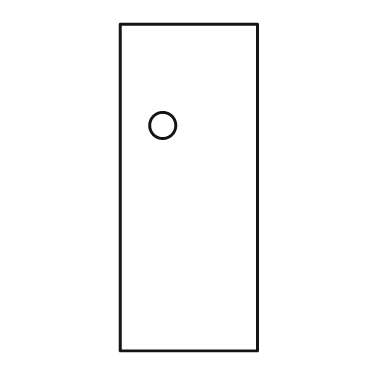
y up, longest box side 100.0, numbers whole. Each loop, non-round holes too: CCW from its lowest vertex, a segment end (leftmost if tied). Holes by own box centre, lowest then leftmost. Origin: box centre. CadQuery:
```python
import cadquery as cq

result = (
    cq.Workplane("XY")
    .moveTo(-21.0, -50.0)
    .lineTo(21.0, -50.0)
    .lineTo(21.0, 50.0)
    .lineTo(-21.0, 50.0)
    .close()
    .moveTo(-8.0, 19.0)
    .circle(4.0)
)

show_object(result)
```